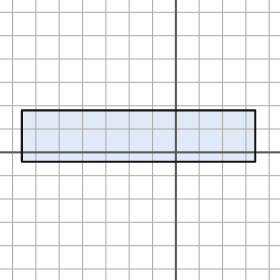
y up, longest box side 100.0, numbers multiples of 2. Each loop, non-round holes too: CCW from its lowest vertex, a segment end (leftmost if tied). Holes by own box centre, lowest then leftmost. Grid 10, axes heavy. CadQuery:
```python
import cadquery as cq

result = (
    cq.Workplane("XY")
    .moveTo(-66.0, -4.0)
    .lineTo(34.0, -4.0)
    .lineTo(34.0, 18.0)
    .lineTo(-66.0, 18.0)
    .close()
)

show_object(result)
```